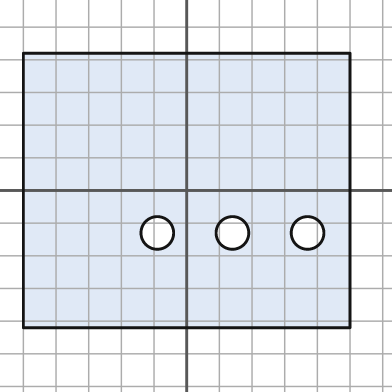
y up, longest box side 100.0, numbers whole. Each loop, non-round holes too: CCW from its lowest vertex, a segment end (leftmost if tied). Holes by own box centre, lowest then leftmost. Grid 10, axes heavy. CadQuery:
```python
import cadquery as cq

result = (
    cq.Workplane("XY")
    .moveTo(-50.0, -42.0)
    .lineTo(50.0, -42.0)
    .lineTo(50.0, 42.0)
    .lineTo(-50.0, 42.0)
    .close()
    .moveTo(-9.0, -13.0)
    .circle(5.0)
    .moveTo(14.0, -13.0)
    .circle(5.0)
    .moveTo(37.0, -13.0)
    .circle(5.0)
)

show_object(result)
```